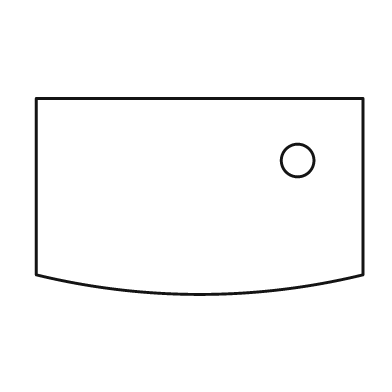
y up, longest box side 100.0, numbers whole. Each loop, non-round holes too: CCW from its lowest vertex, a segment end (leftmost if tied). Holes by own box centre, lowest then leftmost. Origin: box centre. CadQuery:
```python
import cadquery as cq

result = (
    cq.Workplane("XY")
    .moveTo(-50.0, -24.0)
    .threePointArc((0.0, -30.0), (50.0, -24.0))
    .lineTo(50.0, 30.0)
    .lineTo(-50.0, 30.0)
    .close()
    .moveTo(30.0, 11.0)
    .circle(5.0)
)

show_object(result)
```